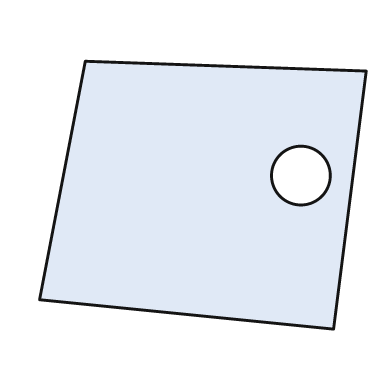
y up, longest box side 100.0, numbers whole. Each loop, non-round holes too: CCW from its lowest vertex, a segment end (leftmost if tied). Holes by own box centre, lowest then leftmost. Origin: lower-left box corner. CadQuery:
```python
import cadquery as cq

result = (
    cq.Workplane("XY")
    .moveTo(90.0, 0.0)
    .lineTo(100.0, 79.0)
    .lineTo(14.0, 82.0)
    .lineTo(0.0, 9.0)
    .close()
    .moveTo(80.0, 47.0)
    .circle(9.0)
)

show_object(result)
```